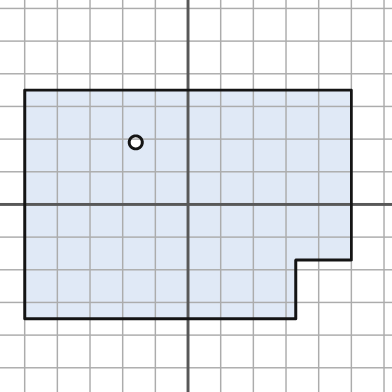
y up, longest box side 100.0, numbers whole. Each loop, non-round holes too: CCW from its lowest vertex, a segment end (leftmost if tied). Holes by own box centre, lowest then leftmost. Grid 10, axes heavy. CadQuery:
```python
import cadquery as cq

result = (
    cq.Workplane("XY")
    .moveTo(-50.0, -35.0)
    .lineTo(33.0, -35.0)
    .lineTo(33.0, -17.0)
    .lineTo(50.0, -17.0)
    .lineTo(50.0, 35.0)
    .lineTo(-50.0, 35.0)
    .close()
    .moveTo(-16.0, 19.0)
    .circle(2.0)
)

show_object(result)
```